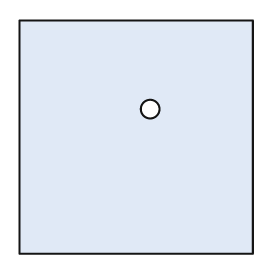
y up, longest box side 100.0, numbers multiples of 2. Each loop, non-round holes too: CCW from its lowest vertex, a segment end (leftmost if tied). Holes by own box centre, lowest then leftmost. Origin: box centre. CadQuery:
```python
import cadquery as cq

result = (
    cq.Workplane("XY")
    .moveTo(-50.0, -50.0)
    .lineTo(50.0, -50.0)
    .lineTo(50.0, 50.0)
    .lineTo(-50.0, 50.0)
    .close()
    .moveTo(6.0, 12.0)
    .circle(4.0)
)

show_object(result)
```